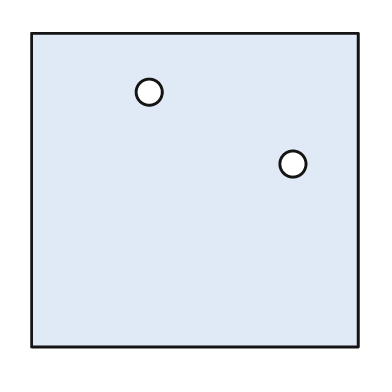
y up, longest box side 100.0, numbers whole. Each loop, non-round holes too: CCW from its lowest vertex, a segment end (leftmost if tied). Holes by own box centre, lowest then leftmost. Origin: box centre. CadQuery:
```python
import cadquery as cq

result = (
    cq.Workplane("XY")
    .moveTo(-50.0, -48.0)
    .lineTo(50.0, -48.0)
    .lineTo(50.0, 48.0)
    .lineTo(-50.0, 48.0)
    .close()
    .moveTo(30.0, 8.0)
    .circle(4.0)
    .moveTo(-14.0, 30.0)
    .circle(4.0)
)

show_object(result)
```